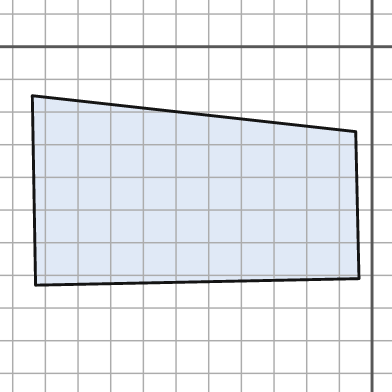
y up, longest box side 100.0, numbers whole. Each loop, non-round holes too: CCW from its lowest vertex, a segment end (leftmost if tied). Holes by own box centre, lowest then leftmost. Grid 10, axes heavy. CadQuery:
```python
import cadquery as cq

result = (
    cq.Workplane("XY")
    .moveTo(-103.0, -73.0)
    .lineTo(-4.0, -71.0)
    .lineTo(-5.0, -26.0)
    .lineTo(-104.0, -15.0)
    .close()
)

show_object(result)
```